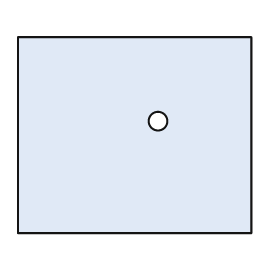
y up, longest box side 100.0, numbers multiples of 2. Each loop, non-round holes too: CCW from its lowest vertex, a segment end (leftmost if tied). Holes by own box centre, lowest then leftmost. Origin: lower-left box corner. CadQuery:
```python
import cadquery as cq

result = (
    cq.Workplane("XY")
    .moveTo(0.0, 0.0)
    .lineTo(100.0, 0.0)
    .lineTo(100.0, 84.0)
    .lineTo(0.0, 84.0)
    .close()
    .moveTo(60.0, 48.0)
    .circle(4.0)
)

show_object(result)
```